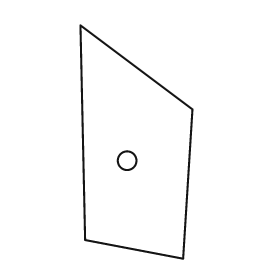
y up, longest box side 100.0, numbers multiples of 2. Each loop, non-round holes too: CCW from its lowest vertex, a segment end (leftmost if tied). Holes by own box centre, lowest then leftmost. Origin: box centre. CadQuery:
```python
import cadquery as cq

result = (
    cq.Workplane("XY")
    .moveTo(20.0, -50.0)
    .lineTo(24.0, 14.0)
    .lineTo(-24.0, 50.0)
    .lineTo(-22.0, -42.0)
    .close()
    .moveTo(-4.0, -8.0)
    .circle(4.0)
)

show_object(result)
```